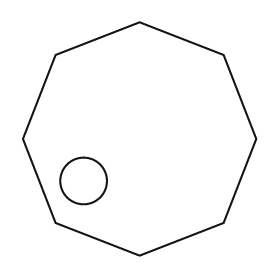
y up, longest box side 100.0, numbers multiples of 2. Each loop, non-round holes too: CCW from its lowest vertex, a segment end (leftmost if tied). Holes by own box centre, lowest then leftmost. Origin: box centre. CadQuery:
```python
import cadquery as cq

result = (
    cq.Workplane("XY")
    .moveTo(0.0, -50.0)
    .lineTo(36.0, -36.0)
    .lineTo(50.0, 0.0)
    .lineTo(36.0, 36.0)
    .lineTo(0.0, 50.0)
    .lineTo(-36.0, 36.0)
    .lineTo(-50.0, 0.0)
    .lineTo(-36.0, -36.0)
    .close()
    .moveTo(-24.0, -18.0)
    .circle(10.0)
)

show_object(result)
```